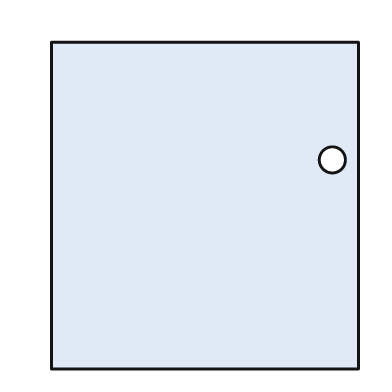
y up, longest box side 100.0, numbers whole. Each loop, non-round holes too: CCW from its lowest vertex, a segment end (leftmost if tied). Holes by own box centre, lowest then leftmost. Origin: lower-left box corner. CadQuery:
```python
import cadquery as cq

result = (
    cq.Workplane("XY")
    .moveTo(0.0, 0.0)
    .lineTo(94.0, 0.0)
    .lineTo(94.0, 100.0)
    .lineTo(0.0, 100.0)
    .close()
    .moveTo(86.0, 64.0)
    .circle(4.0)
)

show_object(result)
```